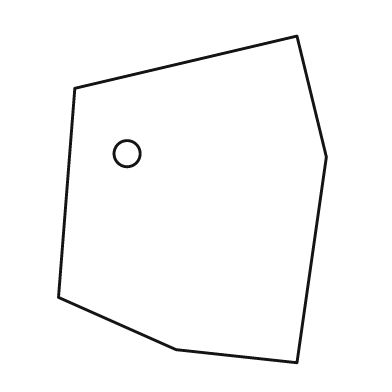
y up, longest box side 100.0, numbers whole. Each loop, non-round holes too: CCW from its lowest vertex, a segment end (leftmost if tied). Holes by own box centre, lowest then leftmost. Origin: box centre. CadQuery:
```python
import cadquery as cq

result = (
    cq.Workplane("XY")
    .moveTo(32.0, -50.0)
    .lineTo(41.0, 13.0)
    .lineTo(32.0, 50.0)
    .lineTo(-36.0, 34.0)
    .lineTo(-41.0, -30.0)
    .lineTo(-5.0, -46.0)
    .close()
    .moveTo(-20.0, 14.0)
    .circle(4.0)
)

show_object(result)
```